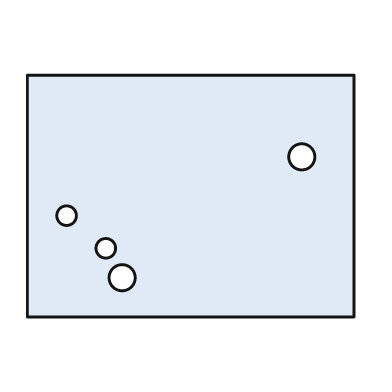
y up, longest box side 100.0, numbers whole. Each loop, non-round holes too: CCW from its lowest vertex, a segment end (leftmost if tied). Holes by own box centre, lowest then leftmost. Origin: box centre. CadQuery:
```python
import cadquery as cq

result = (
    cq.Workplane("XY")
    .moveTo(-50.0, -37.0)
    .lineTo(50.0, -37.0)
    .lineTo(50.0, 37.0)
    .lineTo(-50.0, 37.0)
    .close()
    .moveTo(-21.0, -25.0)
    .circle(4.0)
    .moveTo(-26.0, -16.0)
    .circle(3.0)
    .moveTo(-38.0, -6.0)
    .circle(3.0)
    .moveTo(34.0, 12.0)
    .circle(4.0)
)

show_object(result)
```